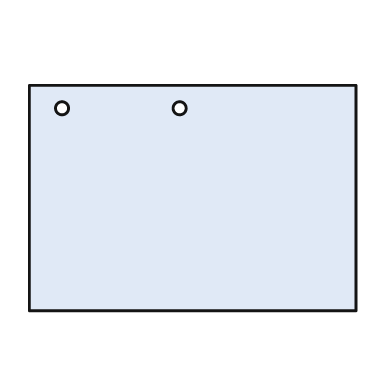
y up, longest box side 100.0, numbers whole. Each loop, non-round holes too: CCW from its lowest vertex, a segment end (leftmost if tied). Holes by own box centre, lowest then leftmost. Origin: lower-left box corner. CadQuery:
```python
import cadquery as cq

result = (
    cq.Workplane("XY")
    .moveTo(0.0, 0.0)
    .lineTo(100.0, 0.0)
    .lineTo(100.0, 69.0)
    .lineTo(0.0, 69.0)
    .close()
    .moveTo(10.0, 62.0)
    .circle(2.0)
    .moveTo(46.0, 62.0)
    .circle(2.0)
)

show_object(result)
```